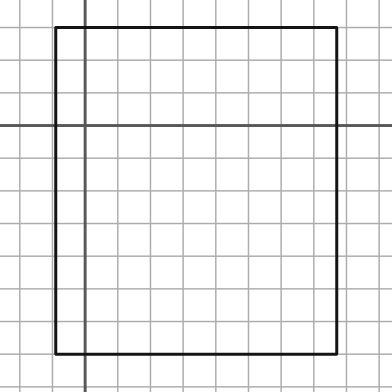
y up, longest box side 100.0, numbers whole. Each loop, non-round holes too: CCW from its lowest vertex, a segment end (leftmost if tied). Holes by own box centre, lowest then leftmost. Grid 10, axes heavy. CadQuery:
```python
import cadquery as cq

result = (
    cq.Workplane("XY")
    .moveTo(-9.0, -70.0)
    .lineTo(77.0, -70.0)
    .lineTo(77.0, 30.0)
    .lineTo(-9.0, 30.0)
    .close()
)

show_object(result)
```